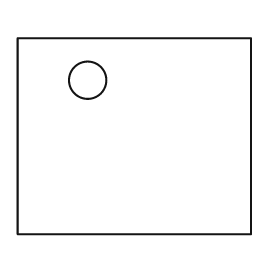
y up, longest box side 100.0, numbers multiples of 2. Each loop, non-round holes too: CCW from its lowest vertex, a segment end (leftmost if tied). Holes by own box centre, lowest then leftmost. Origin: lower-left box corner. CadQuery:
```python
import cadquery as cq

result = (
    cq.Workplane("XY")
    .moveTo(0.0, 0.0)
    .lineTo(100.0, 0.0)
    .lineTo(100.0, 84.0)
    .lineTo(0.0, 84.0)
    .close()
    .moveTo(30.0, 66.0)
    .circle(8.0)
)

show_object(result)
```